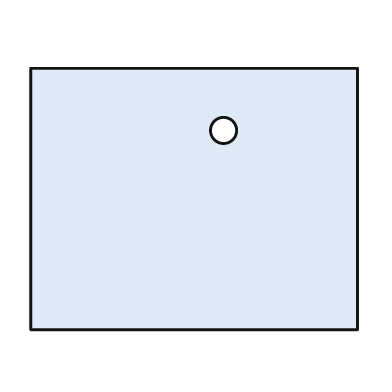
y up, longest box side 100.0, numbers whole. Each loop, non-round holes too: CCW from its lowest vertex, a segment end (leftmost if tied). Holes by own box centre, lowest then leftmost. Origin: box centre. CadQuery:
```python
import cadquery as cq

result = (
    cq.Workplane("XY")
    .moveTo(-50.0, -40.0)
    .lineTo(50.0, -40.0)
    .lineTo(50.0, 40.0)
    .lineTo(-50.0, 40.0)
    .close()
    .moveTo(9.0, 21.0)
    .circle(4.0)
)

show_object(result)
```